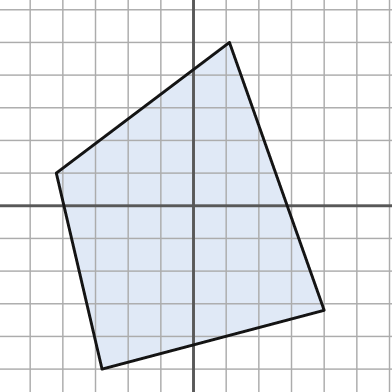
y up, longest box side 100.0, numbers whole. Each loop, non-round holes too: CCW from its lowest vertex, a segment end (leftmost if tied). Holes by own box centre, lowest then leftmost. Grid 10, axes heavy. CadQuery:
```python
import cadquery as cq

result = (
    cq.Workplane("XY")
    .moveTo(-28.0, -50.0)
    .lineTo(40.0, -32.0)
    .lineTo(11.0, 50.0)
    .lineTo(-42.0, 10.0)
    .close()
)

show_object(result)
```